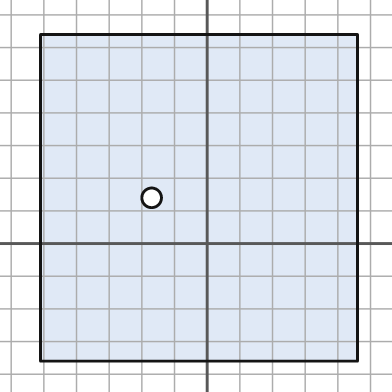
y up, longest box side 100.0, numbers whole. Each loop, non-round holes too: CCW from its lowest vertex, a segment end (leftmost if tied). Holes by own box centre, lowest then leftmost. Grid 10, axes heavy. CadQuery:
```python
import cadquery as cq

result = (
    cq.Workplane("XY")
    .moveTo(-51.0, -36.0)
    .lineTo(46.0, -36.0)
    .lineTo(46.0, 64.0)
    .lineTo(-51.0, 64.0)
    .close()
    .moveTo(-17.0, 14.0)
    .circle(3.0)
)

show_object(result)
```